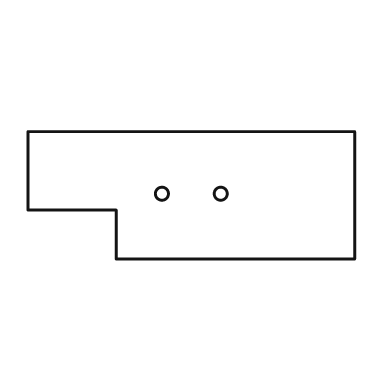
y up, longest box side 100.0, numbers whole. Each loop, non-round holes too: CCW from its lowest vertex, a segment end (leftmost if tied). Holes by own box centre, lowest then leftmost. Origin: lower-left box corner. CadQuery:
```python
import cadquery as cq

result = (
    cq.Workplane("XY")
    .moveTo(27.0, 0.0)
    .lineTo(100.0, 0.0)
    .lineTo(100.0, 39.0)
    .lineTo(0.0, 39.0)
    .lineTo(0.0, 15.0)
    .lineTo(27.0, 15.0)
    .close()
    .moveTo(41.0, 20.0)
    .circle(2.0)
    .moveTo(59.0, 20.0)
    .circle(2.0)
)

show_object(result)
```